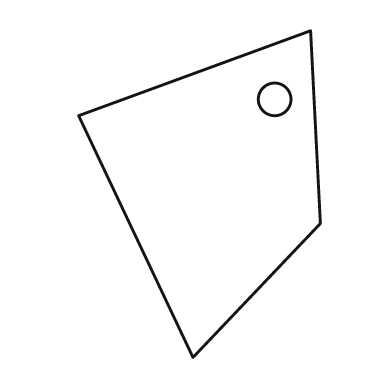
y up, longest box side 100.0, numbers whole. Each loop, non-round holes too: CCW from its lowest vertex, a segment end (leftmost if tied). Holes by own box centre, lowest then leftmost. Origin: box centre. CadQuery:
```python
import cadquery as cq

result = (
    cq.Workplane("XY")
    .moveTo(-2.0, -50.0)
    .lineTo(37.0, -9.0)
    .lineTo(34.0, 50.0)
    .lineTo(-37.0, 24.0)
    .close()
    .moveTo(23.0, 29.0)
    .circle(5.0)
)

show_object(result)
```